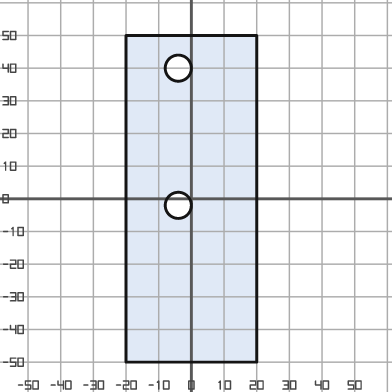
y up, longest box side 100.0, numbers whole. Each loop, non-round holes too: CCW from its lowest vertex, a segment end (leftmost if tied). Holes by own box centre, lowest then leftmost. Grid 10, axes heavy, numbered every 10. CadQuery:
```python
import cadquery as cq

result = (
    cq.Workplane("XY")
    .moveTo(-20.0, -50.0)
    .lineTo(20.0, -50.0)
    .lineTo(20.0, 50.0)
    .lineTo(-20.0, 50.0)
    .close()
    .moveTo(-4.0, -2.0)
    .circle(4.0)
    .moveTo(-4.0, 40.0)
    .circle(4.0)
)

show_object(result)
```